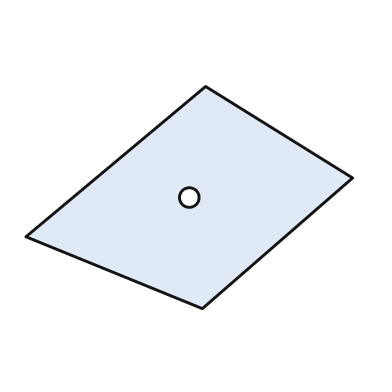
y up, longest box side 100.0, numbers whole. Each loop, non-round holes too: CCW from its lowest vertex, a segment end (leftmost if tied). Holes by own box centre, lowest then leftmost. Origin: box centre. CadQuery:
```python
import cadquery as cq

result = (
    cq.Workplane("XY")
    .moveTo(4.0, -34.0)
    .lineTo(50.0, 6.0)
    .lineTo(5.0, 34.0)
    .lineTo(-50.0, -12.0)
    .close()
    .moveTo(0.0, 0.0)
    .circle(3.0)
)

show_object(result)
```